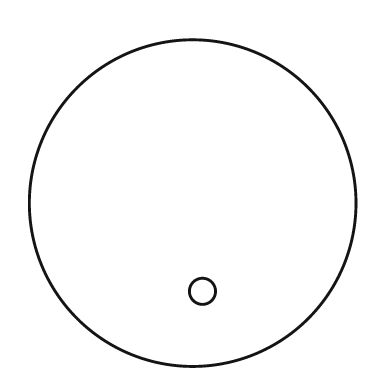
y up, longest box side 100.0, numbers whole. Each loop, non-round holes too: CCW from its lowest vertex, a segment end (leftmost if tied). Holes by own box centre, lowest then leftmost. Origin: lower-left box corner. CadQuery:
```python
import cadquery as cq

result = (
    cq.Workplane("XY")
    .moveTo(50.0, 50.0)
    .circle(50.0)
    .moveTo(53.0, 23.0)
    .circle(4.0)
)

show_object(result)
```